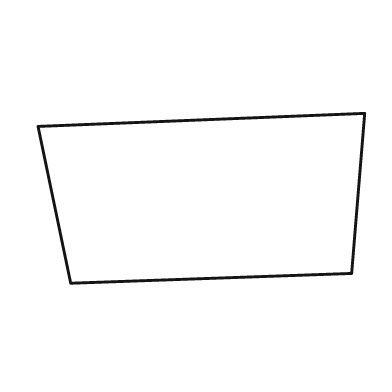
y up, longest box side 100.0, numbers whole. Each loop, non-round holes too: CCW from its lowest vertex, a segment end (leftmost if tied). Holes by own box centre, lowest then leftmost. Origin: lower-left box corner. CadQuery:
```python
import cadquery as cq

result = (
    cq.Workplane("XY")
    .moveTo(10.0, 0.0)
    .lineTo(96.0, 3.0)
    .lineTo(100.0, 52.0)
    .lineTo(0.0, 48.0)
    .close()
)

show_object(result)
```